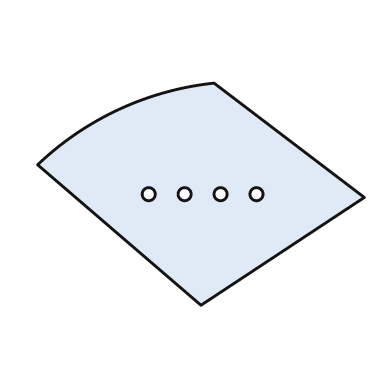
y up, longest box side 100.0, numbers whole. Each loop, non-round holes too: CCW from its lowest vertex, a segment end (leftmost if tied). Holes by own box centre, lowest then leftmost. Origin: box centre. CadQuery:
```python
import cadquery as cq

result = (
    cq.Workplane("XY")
    .moveTo(0.0, -34.0)
    .lineTo(50.0, -1.0)
    .lineTo(4.0, 34.0)
    .threePointArc((-25.0, 26.0), (-50.0, 9.0))
    .close()
    .moveTo(-16.0, 0.0)
    .circle(2.0)
    .moveTo(-5.0, 0.0)
    .circle(2.0)
    .moveTo(6.0, 0.0)
    .circle(2.0)
    .moveTo(17.0, 0.0)
    .circle(2.0)
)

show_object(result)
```